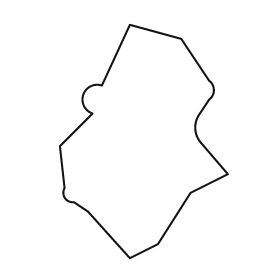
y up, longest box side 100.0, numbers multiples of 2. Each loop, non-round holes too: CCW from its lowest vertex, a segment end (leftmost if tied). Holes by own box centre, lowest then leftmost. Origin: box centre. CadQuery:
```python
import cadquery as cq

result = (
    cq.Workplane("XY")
    .moveTo(-6.0, -50.0)
    .lineTo(6.0, -44.0)
    .lineTo(20.0, -22.0)
    .lineTo(36.0, -14.0)
    .lineTo(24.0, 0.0)
    .threePointArc((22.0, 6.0), (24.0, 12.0))
    .lineTo(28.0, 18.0)
    .threePointArc((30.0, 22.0), (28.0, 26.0))
    .lineTo(16.0, 44.0)
    .lineTo(-6.0, 50.0)
    .lineTo(-18.0, 24.0)
    .threePointArc((-26.0, 20.0), (-22.0, 12.0))
    .lineTo(-36.0, -2.0)
    .lineTo(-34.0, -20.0)
    .threePointArc((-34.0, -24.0), (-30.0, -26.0))
    .lineTo(-24.0, -30.0)
    .close()
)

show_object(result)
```